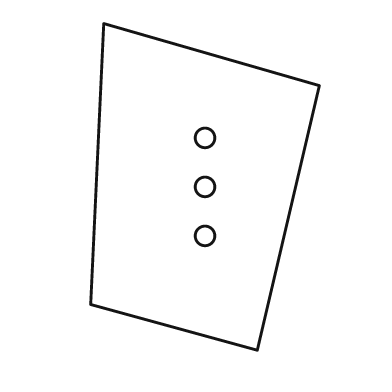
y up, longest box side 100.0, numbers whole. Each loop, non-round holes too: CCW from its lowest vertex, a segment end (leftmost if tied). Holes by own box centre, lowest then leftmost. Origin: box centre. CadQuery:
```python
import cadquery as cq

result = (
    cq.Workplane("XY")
    .moveTo(16.0, -50.0)
    .lineTo(35.0, 31.0)
    .lineTo(-31.0, 50.0)
    .lineTo(-35.0, -36.0)
    .close()
    .moveTo(0.0, -15.0)
    .circle(3.0)
    .moveTo(0.0, 0.0)
    .circle(3.0)
    .moveTo(0.0, 15.0)
    .circle(3.0)
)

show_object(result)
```